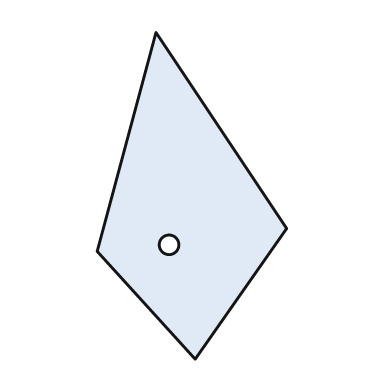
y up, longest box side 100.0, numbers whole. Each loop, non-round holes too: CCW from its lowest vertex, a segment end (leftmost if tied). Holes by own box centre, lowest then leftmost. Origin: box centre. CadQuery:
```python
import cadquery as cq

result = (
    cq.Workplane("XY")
    .moveTo(1.0, -50.0)
    .lineTo(29.0, -10.0)
    .lineTo(-11.0, 50.0)
    .lineTo(-29.0, -17.0)
    .close()
    .moveTo(-7.0, -15.0)
    .circle(3.0)
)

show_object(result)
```